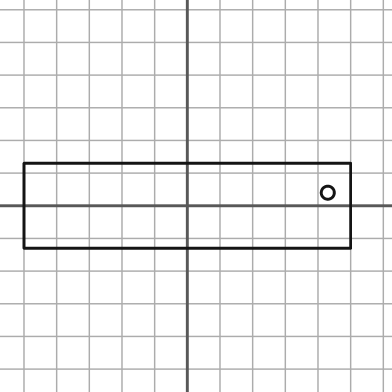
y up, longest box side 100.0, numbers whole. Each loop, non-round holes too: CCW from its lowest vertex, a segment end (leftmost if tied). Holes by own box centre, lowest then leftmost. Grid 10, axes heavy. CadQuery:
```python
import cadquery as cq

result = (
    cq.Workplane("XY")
    .moveTo(-50.0, -13.0)
    .lineTo(50.0, -13.0)
    .lineTo(50.0, 13.0)
    .lineTo(-50.0, 13.0)
    .close()
    .moveTo(43.0, 4.0)
    .circle(2.0)
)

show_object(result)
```